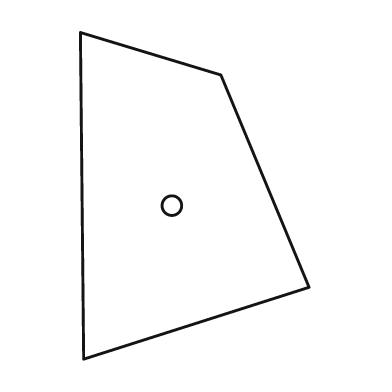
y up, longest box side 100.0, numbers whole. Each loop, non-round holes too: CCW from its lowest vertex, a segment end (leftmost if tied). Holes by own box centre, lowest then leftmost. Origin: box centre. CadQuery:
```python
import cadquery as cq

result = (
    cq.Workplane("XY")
    .moveTo(-34.0, -50.0)
    .lineTo(35.0, -28.0)
    .lineTo(8.0, 37.0)
    .lineTo(-35.0, 50.0)
    .close()
    .moveTo(-7.0, -3.0)
    .circle(3.0)
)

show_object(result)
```